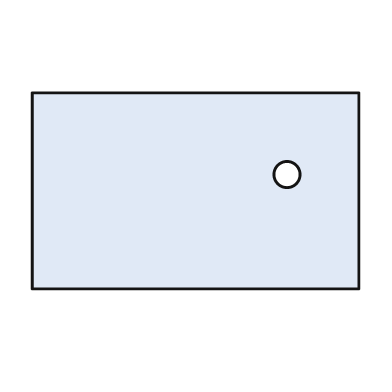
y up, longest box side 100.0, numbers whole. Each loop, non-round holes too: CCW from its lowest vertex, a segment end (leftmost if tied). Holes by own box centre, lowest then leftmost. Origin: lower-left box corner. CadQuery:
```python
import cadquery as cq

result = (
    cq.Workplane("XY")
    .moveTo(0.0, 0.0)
    .lineTo(100.0, 0.0)
    .lineTo(100.0, 60.0)
    .lineTo(0.0, 60.0)
    .close()
    .moveTo(78.0, 35.0)
    .circle(4.0)
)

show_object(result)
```